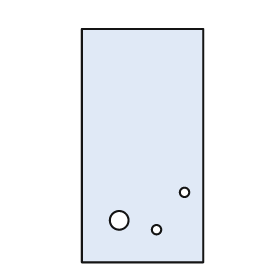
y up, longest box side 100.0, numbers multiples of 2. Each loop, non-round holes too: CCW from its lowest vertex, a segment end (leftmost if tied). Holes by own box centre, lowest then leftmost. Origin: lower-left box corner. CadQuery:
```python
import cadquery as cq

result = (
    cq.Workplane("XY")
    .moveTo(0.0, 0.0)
    .lineTo(52.0, 0.0)
    .lineTo(52.0, 100.0)
    .lineTo(0.0, 100.0)
    .close()
    .moveTo(32.0, 14.0)
    .circle(2.0)
    .moveTo(16.0, 18.0)
    .circle(4.0)
    .moveTo(44.0, 30.0)
    .circle(2.0)
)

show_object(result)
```